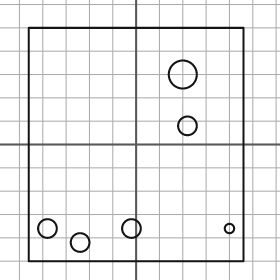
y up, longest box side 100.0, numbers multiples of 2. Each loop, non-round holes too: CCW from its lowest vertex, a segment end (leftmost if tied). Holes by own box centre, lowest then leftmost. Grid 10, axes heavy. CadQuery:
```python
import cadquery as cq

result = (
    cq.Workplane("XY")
    .moveTo(-46.0, -50.0)
    .lineTo(46.0, -50.0)
    .lineTo(46.0, 50.0)
    .lineTo(-46.0, 50.0)
    .close()
    .moveTo(-24.0, -42.0)
    .circle(4.0)
    .moveTo(-38.0, -36.0)
    .circle(4.0)
    .moveTo(-2.0, -36.0)
    .circle(4.0)
    .moveTo(40.0, -36.0)
    .circle(2.0)
    .moveTo(22.0, 8.0)
    .circle(4.0)
    .moveTo(20.0, 30.0)
    .circle(6.0)
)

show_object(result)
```